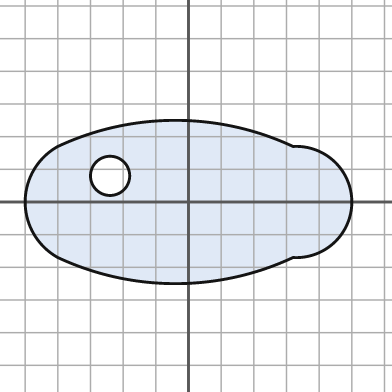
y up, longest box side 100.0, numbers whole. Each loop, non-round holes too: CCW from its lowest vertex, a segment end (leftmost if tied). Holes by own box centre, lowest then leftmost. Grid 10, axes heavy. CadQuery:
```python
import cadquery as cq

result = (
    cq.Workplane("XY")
    .moveTo(-40.0, -17.0)
    .threePointArc((-4.0, -25.0), (32.0, -17.0))
    .threePointArc((50.0, 0.0), (32.0, 17.0))
    .threePointArc((-4.0, 25.0), (-40.0, 17.0))
    .threePointArc((-50.0, 0.0), (-40.0, -17.0))
    .close()
    .moveTo(-24.0, 8.0)
    .circle(6.0)
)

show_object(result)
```